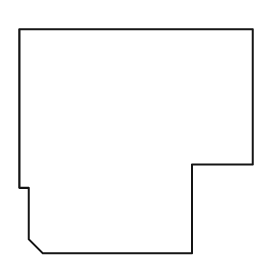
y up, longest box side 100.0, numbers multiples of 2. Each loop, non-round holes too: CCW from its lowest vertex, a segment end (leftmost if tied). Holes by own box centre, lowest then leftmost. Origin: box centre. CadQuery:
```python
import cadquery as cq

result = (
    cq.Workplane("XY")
    .moveTo(-40.0, -48.0)
    .lineTo(24.0, -48.0)
    .lineTo(24.0, -10.0)
    .lineTo(50.0, -10.0)
    .lineTo(50.0, 48.0)
    .lineTo(-50.0, 48.0)
    .lineTo(-50.0, -20.0)
    .lineTo(-46.0, -20.0)
    .lineTo(-46.0, -42.0)
    .close()
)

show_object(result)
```